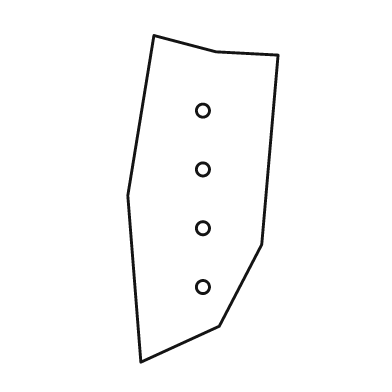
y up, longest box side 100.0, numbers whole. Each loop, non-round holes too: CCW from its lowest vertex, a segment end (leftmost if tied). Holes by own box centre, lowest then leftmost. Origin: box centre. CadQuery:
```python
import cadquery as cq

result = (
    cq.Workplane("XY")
    .moveTo(-19.0, -50.0)
    .lineTo(5.0, -39.0)
    .lineTo(18.0, -14.0)
    .lineTo(23.0, 44.0)
    .lineTo(4.0, 45.0)
    .lineTo(-15.0, 50.0)
    .lineTo(-23.0, 1.0)
    .close()
    .moveTo(0.0, -27.0)
    .circle(2.0)
    .moveTo(0.0, -9.0)
    .circle(2.0)
    .moveTo(0.0, 9.0)
    .circle(2.0)
    .moveTo(0.0, 27.0)
    .circle(2.0)
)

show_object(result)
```